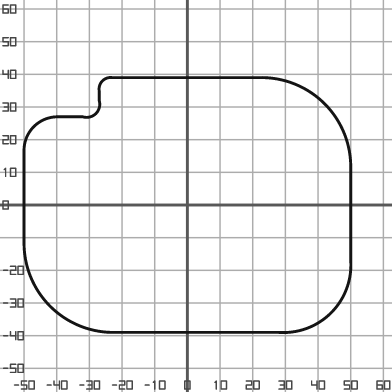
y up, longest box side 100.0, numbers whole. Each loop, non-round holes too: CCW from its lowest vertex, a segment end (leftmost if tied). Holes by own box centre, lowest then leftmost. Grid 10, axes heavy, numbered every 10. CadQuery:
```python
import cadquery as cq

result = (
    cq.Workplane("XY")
    .moveTo(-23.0, -39.0)
    .lineTo(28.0, -39.0)
    .threePointArc((44.0, -33.0), (50.0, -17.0))
    .lineTo(50.0, 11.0)
    .threePointArc((42.0, 31.0), (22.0, 39.0))
    .lineTo(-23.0, 39.0)
    .threePointArc((-26.0, 38.0), (-27.0, 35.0))
    .lineTo(-27.0, 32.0)
    .threePointArc((-28.0, 28.0), (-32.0, 27.0))
    .lineTo(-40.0, 27.0)
    .threePointArc((-47.0, 24.0), (-50.0, 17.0))
    .lineTo(-50.0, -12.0)
    .threePointArc((-42.0, -31.0), (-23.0, -39.0))
    .close()
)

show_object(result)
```